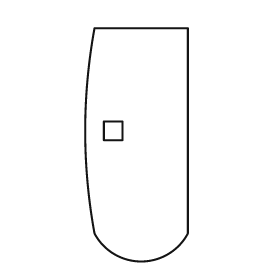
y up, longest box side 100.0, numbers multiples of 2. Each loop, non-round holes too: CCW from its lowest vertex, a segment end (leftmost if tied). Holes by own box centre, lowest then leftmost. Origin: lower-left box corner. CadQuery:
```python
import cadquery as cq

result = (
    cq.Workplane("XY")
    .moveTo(4.0, 12.0)
    .threePointArc((24.0, 0.0), (44.0, 12.0))
    .lineTo(44.0, 100.0)
    .lineTo(4.0, 100.0)
    .threePointArc((0.0, 56.0), (4.0, 12.0))
    .close()
    .moveTo(8.0, 52.0)
    .lineTo(16.0, 52.0)
    .lineTo(16.0, 60.0)
    .lineTo(8.0, 60.0)
    .close()
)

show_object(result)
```